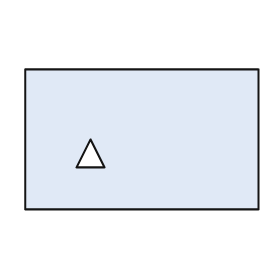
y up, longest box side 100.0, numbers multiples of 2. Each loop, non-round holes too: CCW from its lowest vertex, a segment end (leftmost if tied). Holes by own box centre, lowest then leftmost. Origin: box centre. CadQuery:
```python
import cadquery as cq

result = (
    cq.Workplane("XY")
    .moveTo(-50.0, -30.0)
    .lineTo(50.0, -30.0)
    .lineTo(50.0, 30.0)
    .lineTo(-50.0, 30.0)
    .close()
    .moveTo(-28.0, -12.0)
    .lineTo(-16.0, -12.0)
    .lineTo(-22.0, 0.0)
    .close()
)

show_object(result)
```